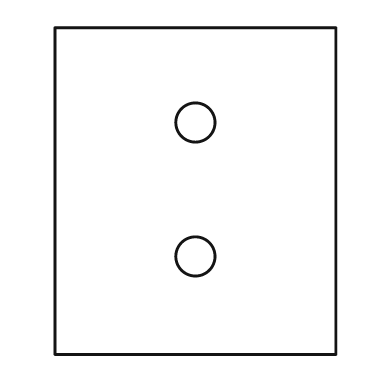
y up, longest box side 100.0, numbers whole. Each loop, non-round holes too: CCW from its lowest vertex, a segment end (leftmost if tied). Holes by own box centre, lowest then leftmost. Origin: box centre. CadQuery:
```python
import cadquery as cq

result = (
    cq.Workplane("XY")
    .moveTo(-43.0, -50.0)
    .lineTo(43.0, -50.0)
    .lineTo(43.0, 50.0)
    .lineTo(-43.0, 50.0)
    .close()
    .moveTo(0.0, -20.0)
    .circle(6.0)
    .moveTo(0.0, 21.0)
    .circle(6.0)
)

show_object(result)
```